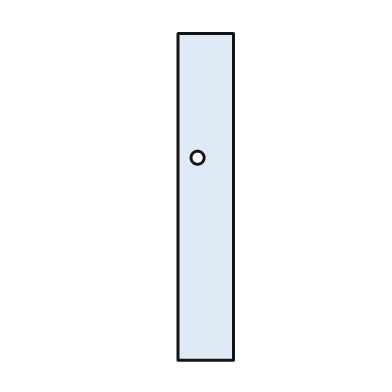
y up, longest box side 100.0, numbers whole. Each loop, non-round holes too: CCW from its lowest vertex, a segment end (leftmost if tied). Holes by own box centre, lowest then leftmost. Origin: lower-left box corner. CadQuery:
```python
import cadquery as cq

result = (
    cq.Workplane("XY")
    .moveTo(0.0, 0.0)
    .lineTo(17.0, 0.0)
    .lineTo(17.0, 100.0)
    .lineTo(0.0, 100.0)
    .close()
    .moveTo(6.0, 62.0)
    .circle(2.0)
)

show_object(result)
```